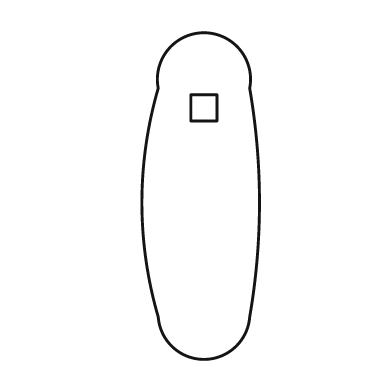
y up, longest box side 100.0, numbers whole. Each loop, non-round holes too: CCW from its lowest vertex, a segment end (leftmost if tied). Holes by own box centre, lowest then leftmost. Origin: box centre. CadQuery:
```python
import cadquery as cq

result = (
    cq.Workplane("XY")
    .moveTo(-13.0, -37.0)
    .threePointArc((1.0, -50.0), (15.0, -37.0))
    .threePointArc((18.0, -2.0), (15.0, 33.0))
    .threePointArc((1.0, 50.0), (-13.0, 33.0))
    .threePointArc((-18.0, -2.0), (-13.0, -37.0))
    .close()
    .moveTo(-3.0, 23.0)
    .lineTo(5.0, 23.0)
    .lineTo(5.0, 31.0)
    .lineTo(-3.0, 31.0)
    .close()
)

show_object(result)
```